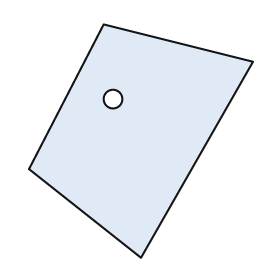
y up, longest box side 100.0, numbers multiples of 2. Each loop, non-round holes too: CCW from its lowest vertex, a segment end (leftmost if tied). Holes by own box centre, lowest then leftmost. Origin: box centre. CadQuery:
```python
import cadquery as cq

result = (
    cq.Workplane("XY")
    .moveTo(0.0, -50.0)
    .lineTo(48.0, 34.0)
    .lineTo(-16.0, 50.0)
    .lineTo(-48.0, -12.0)
    .close()
    .moveTo(-12.0, 18.0)
    .circle(4.0)
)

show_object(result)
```